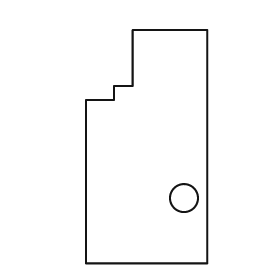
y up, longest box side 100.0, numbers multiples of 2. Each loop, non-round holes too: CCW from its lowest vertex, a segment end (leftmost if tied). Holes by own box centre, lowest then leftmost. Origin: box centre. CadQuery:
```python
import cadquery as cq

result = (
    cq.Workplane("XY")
    .moveTo(-26.0, -50.0)
    .lineTo(26.0, -50.0)
    .lineTo(26.0, 50.0)
    .lineTo(-6.0, 50.0)
    .lineTo(-6.0, 26.0)
    .lineTo(-14.0, 26.0)
    .lineTo(-14.0, 20.0)
    .lineTo(-26.0, 20.0)
    .close()
    .moveTo(16.0, -22.0)
    .circle(6.0)
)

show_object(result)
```